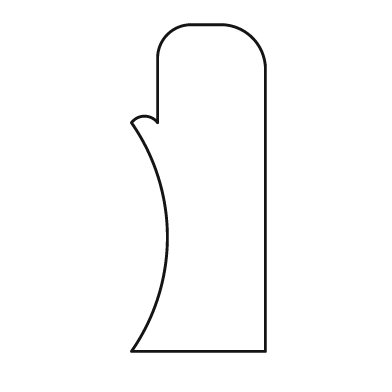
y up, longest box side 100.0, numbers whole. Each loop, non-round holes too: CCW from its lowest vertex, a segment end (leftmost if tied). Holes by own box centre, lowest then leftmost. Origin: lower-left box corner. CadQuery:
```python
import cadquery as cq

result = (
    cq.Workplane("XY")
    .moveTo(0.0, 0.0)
    .lineTo(41.0, 0.0)
    .lineTo(41.0, 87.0)
    .threePointArc((37.0, 96.0), (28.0, 100.0))
    .lineTo(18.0, 100.0)
    .threePointArc((11.0, 97.0), (8.0, 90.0))
    .lineTo(8.0, 70.0)
    .threePointArc((4.0, 72.0), (0.0, 70.0))
    .threePointArc((11.0, 35.0), (0.0, 0.0))
    .close()
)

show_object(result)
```